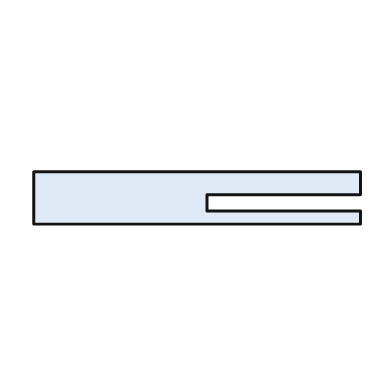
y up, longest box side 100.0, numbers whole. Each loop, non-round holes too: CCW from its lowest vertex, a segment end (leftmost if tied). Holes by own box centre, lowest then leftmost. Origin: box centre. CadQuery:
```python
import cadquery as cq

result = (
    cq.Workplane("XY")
    .moveTo(-50.0, -8.0)
    .lineTo(50.0, -8.0)
    .lineTo(50.0, -4.0)
    .lineTo(3.0, -4.0)
    .lineTo(3.0, 1.0)
    .lineTo(50.0, 1.0)
    .lineTo(50.0, 8.0)
    .lineTo(-50.0, 8.0)
    .close()
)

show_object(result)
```